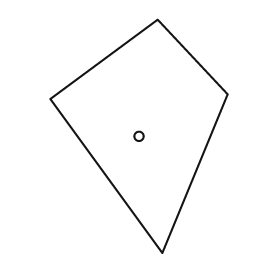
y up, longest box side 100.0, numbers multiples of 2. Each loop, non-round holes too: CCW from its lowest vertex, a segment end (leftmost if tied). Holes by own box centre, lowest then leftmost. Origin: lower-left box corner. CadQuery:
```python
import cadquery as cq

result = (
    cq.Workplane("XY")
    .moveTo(48.0, 0.0)
    .lineTo(76.0, 68.0)
    .lineTo(46.0, 100.0)
    .lineTo(0.0, 66.0)
    .close()
    .moveTo(38.0, 50.0)
    .circle(2.0)
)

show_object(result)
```